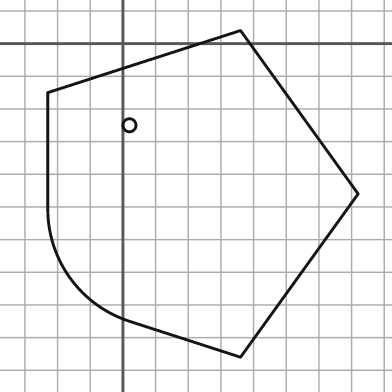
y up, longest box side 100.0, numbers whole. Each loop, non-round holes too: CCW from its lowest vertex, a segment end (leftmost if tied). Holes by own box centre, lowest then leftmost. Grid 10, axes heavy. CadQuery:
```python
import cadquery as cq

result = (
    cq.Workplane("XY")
    .moveTo(36.0, -96.0)
    .lineTo(72.0, -46.0)
    .lineTo(36.0, 4.0)
    .lineTo(-23.0, -15.0)
    .lineTo(-23.0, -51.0)
    .threePointArc((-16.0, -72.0), (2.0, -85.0))
    .close()
    .moveTo(2.0, -25.0)
    .circle(2.0)
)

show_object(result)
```